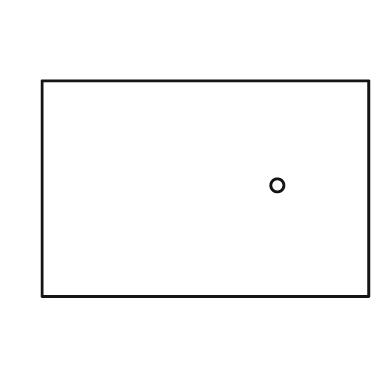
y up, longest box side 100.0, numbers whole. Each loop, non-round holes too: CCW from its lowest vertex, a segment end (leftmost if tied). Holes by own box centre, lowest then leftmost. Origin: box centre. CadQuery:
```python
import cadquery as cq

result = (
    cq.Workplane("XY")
    .moveTo(-50.0, -33.0)
    .lineTo(50.0, -33.0)
    .lineTo(50.0, 33.0)
    .lineTo(-50.0, 33.0)
    .close()
    .moveTo(22.0, 1.0)
    .circle(2.0)
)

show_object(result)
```